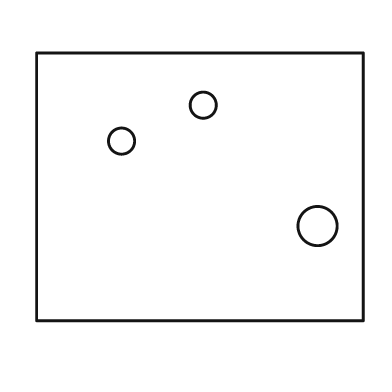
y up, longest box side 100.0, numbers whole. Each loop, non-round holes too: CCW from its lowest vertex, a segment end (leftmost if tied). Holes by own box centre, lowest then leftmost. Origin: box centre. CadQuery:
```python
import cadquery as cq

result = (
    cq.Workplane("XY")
    .moveTo(-50.0, -41.0)
    .lineTo(50.0, -41.0)
    .lineTo(50.0, 41.0)
    .lineTo(-50.0, 41.0)
    .close()
    .moveTo(36.0, -12.0)
    .circle(6.0)
    .moveTo(-24.0, 14.0)
    .circle(4.0)
    .moveTo(1.0, 25.0)
    .circle(4.0)
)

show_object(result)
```